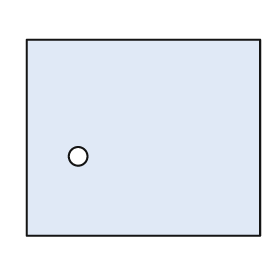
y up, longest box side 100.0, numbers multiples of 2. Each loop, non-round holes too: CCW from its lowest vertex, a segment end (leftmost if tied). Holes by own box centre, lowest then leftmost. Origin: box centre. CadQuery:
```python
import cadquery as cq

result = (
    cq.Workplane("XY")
    .moveTo(-50.0, -42.0)
    .lineTo(50.0, -42.0)
    .lineTo(50.0, 42.0)
    .lineTo(-50.0, 42.0)
    .close()
    .moveTo(-28.0, -8.0)
    .circle(4.0)
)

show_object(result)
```